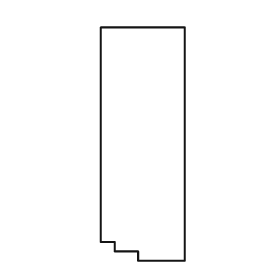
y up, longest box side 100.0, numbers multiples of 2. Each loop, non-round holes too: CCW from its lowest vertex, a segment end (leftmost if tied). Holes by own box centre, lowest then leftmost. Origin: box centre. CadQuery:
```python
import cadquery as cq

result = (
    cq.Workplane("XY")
    .moveTo(-2.0, -50.0)
    .lineTo(18.0, -50.0)
    .lineTo(18.0, 50.0)
    .lineTo(-18.0, 50.0)
    .lineTo(-18.0, -42.0)
    .lineTo(-12.0, -42.0)
    .lineTo(-12.0, -46.0)
    .lineTo(-2.0, -46.0)
    .close()
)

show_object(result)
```